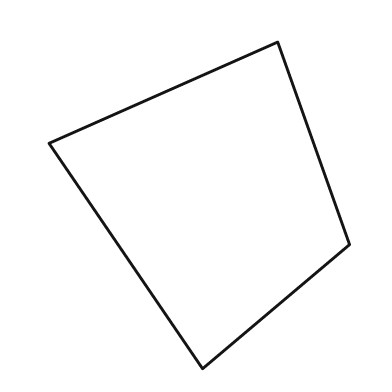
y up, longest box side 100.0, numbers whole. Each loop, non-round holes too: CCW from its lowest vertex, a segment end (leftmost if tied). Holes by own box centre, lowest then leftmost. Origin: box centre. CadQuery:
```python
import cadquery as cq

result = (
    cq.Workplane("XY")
    .moveTo(1.0, -50.0)
    .lineTo(46.0, -12.0)
    .lineTo(24.0, 50.0)
    .lineTo(-46.0, 19.0)
    .close()
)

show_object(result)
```